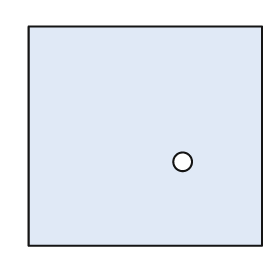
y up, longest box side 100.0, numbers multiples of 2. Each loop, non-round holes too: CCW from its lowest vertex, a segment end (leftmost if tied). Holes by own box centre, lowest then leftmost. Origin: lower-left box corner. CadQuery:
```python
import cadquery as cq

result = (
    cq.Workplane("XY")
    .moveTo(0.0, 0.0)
    .lineTo(100.0, 0.0)
    .lineTo(100.0, 94.0)
    .lineTo(0.0, 94.0)
    .close()
    .moveTo(66.0, 36.0)
    .circle(4.0)
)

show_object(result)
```